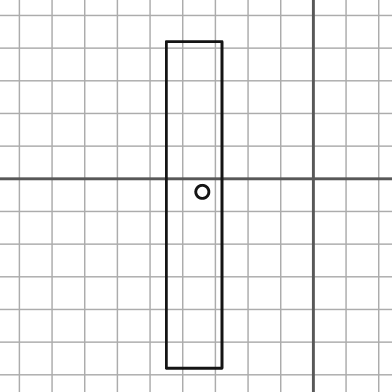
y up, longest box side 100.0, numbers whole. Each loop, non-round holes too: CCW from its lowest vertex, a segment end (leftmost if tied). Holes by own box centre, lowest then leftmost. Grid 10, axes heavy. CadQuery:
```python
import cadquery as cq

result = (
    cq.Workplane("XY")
    .moveTo(-45.0, -58.0)
    .lineTo(-28.0, -58.0)
    .lineTo(-28.0, 42.0)
    .lineTo(-45.0, 42.0)
    .close()
    .moveTo(-34.0, -4.0)
    .circle(2.0)
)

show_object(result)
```